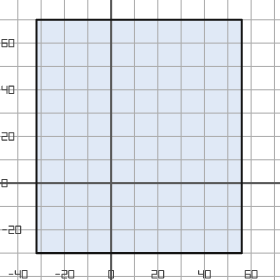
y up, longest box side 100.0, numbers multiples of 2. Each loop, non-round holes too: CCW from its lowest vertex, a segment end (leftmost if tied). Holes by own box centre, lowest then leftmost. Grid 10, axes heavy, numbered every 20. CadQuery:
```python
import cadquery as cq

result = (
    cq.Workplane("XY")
    .moveTo(-32.0, -30.0)
    .lineTo(56.0, -30.0)
    .lineTo(56.0, 70.0)
    .lineTo(-32.0, 70.0)
    .close()
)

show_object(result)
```